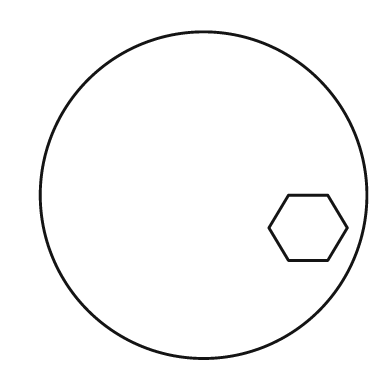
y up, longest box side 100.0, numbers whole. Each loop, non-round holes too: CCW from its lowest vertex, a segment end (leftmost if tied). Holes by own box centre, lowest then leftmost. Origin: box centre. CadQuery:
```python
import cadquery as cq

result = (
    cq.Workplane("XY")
    .moveTo(0.0, 0.0)
    .circle(50.0)
    .moveTo(26.0, -20.0)
    .lineTo(38.0, -20.0)
    .lineTo(44.0, -10.0)
    .lineTo(38.0, 0.0)
    .lineTo(26.0, 0.0)
    .lineTo(20.0, -10.0)
    .close()
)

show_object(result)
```